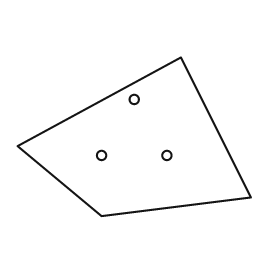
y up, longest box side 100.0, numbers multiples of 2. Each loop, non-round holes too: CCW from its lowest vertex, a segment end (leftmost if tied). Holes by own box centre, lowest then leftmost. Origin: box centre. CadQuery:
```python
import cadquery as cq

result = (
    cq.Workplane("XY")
    .moveTo(-14.0, -34.0)
    .lineTo(50.0, -26.0)
    .lineTo(20.0, 34.0)
    .lineTo(-50.0, -4.0)
    .close()
    .moveTo(-14.0, -8.0)
    .circle(2.0)
    .moveTo(14.0, -8.0)
    .circle(2.0)
    .moveTo(0.0, 16.0)
    .circle(2.0)
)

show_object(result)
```